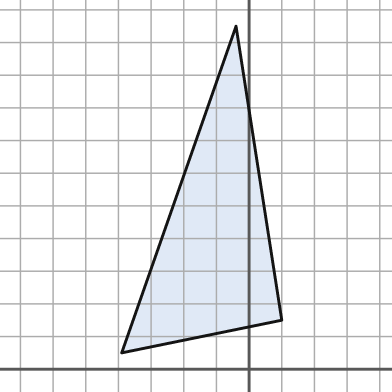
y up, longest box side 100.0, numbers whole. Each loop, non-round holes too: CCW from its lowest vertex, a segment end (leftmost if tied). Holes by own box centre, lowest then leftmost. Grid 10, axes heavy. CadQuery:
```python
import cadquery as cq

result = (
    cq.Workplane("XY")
    .moveTo(-39.0, 5.0)
    .lineTo(10.0, 15.0)
    .lineTo(-4.0, 105.0)
    .close()
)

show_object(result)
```